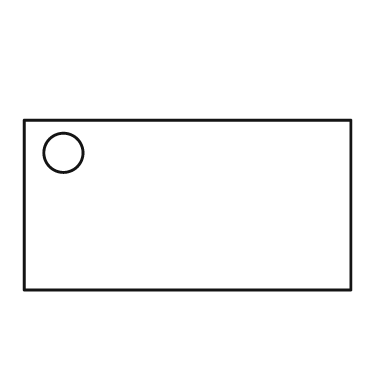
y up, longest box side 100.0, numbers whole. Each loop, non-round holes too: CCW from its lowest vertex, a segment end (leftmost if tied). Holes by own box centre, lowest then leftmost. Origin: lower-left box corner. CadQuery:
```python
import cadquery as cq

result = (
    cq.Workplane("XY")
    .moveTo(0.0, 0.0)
    .lineTo(100.0, 0.0)
    .lineTo(100.0, 52.0)
    .lineTo(0.0, 52.0)
    .close()
    .moveTo(12.0, 42.0)
    .circle(6.0)
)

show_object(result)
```